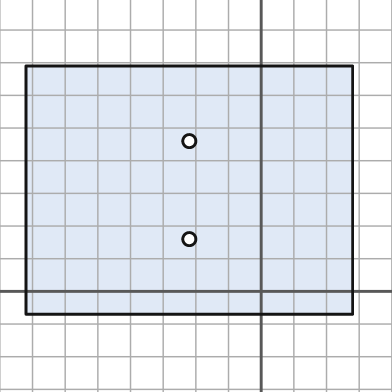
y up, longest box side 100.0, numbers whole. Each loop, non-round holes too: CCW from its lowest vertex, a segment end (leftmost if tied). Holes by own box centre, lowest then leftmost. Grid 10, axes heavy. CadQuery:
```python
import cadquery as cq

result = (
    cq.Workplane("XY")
    .moveTo(-72.0, -7.0)
    .lineTo(28.0, -7.0)
    .lineTo(28.0, 69.0)
    .lineTo(-72.0, 69.0)
    .close()
    .moveTo(-22.0, 16.0)
    .circle(2.0)
    .moveTo(-22.0, 46.0)
    .circle(2.0)
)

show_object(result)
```